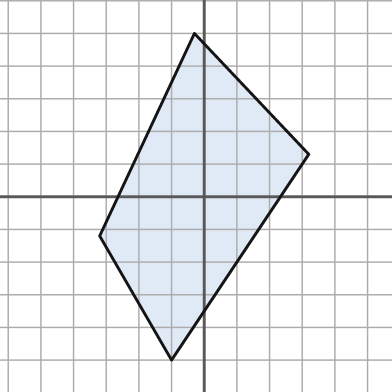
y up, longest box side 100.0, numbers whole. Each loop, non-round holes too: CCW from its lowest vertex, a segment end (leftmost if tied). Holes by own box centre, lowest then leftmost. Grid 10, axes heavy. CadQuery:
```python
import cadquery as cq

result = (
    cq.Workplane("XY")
    .moveTo(-10.0, -50.0)
    .lineTo(32.0, 13.0)
    .lineTo(-3.0, 50.0)
    .lineTo(-32.0, -12.0)
    .close()
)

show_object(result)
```